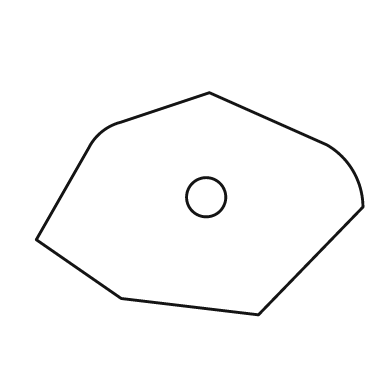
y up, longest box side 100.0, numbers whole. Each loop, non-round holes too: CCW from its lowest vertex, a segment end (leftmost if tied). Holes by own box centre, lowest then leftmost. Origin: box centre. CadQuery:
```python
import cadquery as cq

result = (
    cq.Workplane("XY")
    .moveTo(18.0, -34.0)
    .lineTo(50.0, -1.0)
    .threePointArc((47.0, 10.0), (39.0, 18.0))
    .lineTo(3.0, 34.0)
    .lineTo(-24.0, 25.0)
    .threePointArc((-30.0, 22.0), (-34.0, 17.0))
    .lineTo(-50.0, -11.0)
    .lineTo(-24.0, -29.0)
    .close()
    .moveTo(2.0, 2.0)
    .circle(6.0)
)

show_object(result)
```